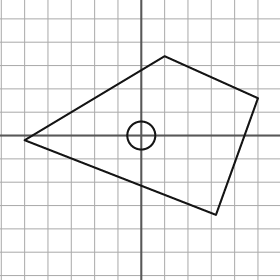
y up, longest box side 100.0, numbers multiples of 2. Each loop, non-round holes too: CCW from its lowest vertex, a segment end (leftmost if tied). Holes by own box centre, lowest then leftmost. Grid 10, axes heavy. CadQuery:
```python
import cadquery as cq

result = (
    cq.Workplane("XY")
    .moveTo(32.0, -34.0)
    .lineTo(50.0, 16.0)
    .lineTo(10.0, 34.0)
    .lineTo(-50.0, -2.0)
    .close()
    .moveTo(0.0, 0.0)
    .circle(6.0)
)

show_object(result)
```